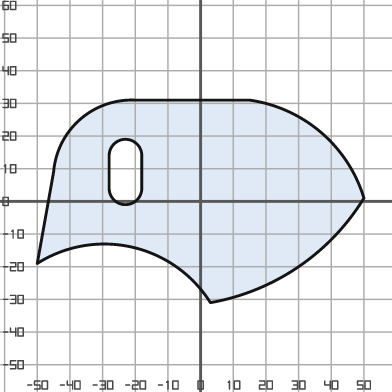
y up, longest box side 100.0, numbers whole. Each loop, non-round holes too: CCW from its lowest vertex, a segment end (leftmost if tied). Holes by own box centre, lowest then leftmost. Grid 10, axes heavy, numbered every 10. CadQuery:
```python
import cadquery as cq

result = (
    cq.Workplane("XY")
    .moveTo(3.0, -31.0)
    .threePointArc((30.0, -20.0), (50.0, 1.0))
    .threePointArc((37.0, 21.0), (15.0, 31.0))
    .lineTo(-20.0, 31.0)
    .threePointArc((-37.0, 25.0), (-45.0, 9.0))
    .lineTo(-50.0, -19.0)
    .threePointArc((-21.0, -14.0), (3.0, -31.0))
    .close()
    .moveTo(-28.0, 4.0)
    .threePointArc((-23.0, -1.0), (-18.0, 4.0))
    .lineTo(-18.0, 14.0)
    .threePointArc((-23.0, 19.0), (-28.0, 14.0))
    .close()
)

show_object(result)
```